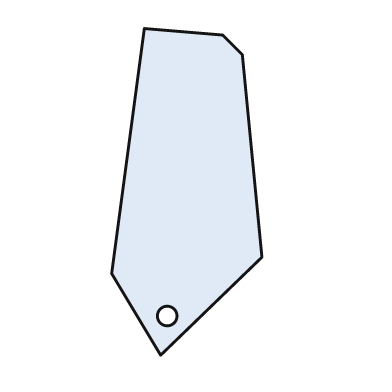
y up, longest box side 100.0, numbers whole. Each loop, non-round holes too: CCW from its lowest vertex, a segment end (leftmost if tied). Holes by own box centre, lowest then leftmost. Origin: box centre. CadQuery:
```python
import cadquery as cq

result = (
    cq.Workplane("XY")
    .moveTo(-8.0, -50.0)
    .lineTo(23.0, -20.0)
    .lineTo(17.0, 42.0)
    .lineTo(11.0, 48.0)
    .lineTo(-13.0, 50.0)
    .lineTo(-23.0, -25.0)
    .close()
    .moveTo(-6.0, -38.0)
    .circle(3.0)
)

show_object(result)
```